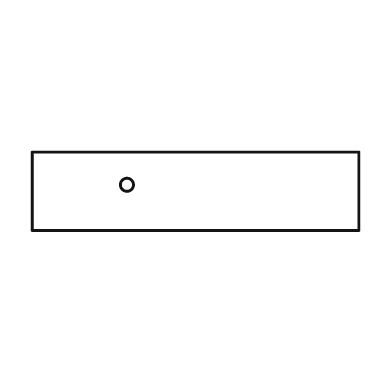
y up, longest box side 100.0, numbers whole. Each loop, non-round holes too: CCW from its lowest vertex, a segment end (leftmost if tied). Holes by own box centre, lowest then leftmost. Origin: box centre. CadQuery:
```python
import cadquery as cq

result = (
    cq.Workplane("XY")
    .moveTo(-50.0, -12.0)
    .lineTo(50.0, -12.0)
    .lineTo(50.0, 12.0)
    .lineTo(-50.0, 12.0)
    .close()
    .moveTo(-21.0, 2.0)
    .circle(2.0)
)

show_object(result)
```